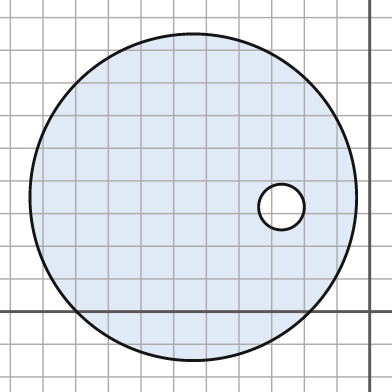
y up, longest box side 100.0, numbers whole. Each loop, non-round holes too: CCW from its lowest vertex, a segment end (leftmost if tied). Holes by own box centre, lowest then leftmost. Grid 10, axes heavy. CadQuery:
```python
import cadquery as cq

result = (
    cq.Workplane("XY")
    .moveTo(-54.0, 35.0)
    .circle(50.0)
    .moveTo(-27.0, 32.0)
    .circle(7.0)
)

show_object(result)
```